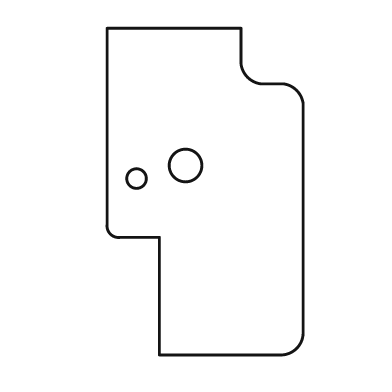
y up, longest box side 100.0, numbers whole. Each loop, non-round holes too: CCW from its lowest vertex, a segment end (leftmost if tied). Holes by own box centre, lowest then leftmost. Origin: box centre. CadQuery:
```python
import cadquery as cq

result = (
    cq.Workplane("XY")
    .moveTo(-14.0, -50.0)
    .lineTo(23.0, -50.0)
    .threePointArc((28.0, -48.0), (30.0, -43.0))
    .lineTo(30.0, 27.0)
    .threePointArc((28.0, 31.0), (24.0, 33.0))
    .lineTo(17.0, 33.0)
    .threePointArc((13.0, 35.0), (11.0, 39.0))
    .lineTo(11.0, 50.0)
    .lineTo(-30.0, 50.0)
    .lineTo(-30.0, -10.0)
    .threePointArc((-29.0, -13.0), (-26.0, -14.0))
    .lineTo(-14.0, -14.0)
    .close()
    .moveTo(-21.0, 4.0)
    .circle(3.0)
    .moveTo(-6.0, 8.0)
    .circle(5.0)
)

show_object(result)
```